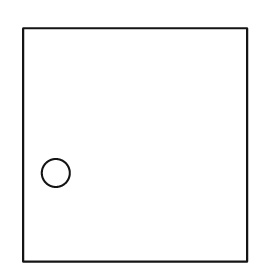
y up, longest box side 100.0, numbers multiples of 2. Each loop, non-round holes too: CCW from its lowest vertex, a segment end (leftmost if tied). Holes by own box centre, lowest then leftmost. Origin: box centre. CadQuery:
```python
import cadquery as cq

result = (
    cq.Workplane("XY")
    .moveTo(-48.0, -50.0)
    .lineTo(48.0, -50.0)
    .lineTo(48.0, 50.0)
    .lineTo(-48.0, 50.0)
    .close()
    .moveTo(-34.0, -12.0)
    .circle(6.0)
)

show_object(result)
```